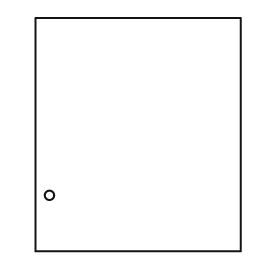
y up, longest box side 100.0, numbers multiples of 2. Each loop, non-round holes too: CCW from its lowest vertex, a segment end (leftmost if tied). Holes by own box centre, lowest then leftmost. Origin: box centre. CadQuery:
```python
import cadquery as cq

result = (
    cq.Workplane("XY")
    .moveTo(-44.0, -50.0)
    .lineTo(44.0, -50.0)
    .lineTo(44.0, 50.0)
    .lineTo(-44.0, 50.0)
    .close()
    .moveTo(-38.0, -26.0)
    .circle(2.0)
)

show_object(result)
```